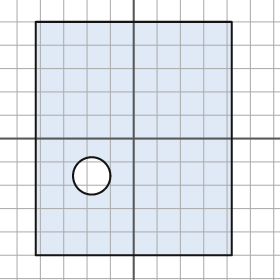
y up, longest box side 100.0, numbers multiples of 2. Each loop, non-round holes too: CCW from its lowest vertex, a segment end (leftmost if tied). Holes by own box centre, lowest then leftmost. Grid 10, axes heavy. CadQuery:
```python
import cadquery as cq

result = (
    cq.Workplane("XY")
    .moveTo(-42.0, -50.0)
    .lineTo(42.0, -50.0)
    .lineTo(42.0, 50.0)
    .lineTo(-42.0, 50.0)
    .close()
    .moveTo(-18.0, -16.0)
    .circle(8.0)
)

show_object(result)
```